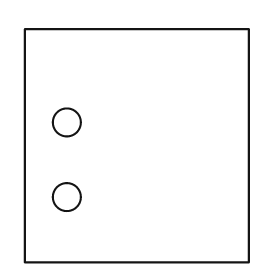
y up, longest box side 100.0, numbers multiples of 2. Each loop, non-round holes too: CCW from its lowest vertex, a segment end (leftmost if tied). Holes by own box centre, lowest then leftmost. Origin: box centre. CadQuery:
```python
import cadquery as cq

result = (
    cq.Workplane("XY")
    .moveTo(-48.0, -50.0)
    .lineTo(48.0, -50.0)
    .lineTo(48.0, 50.0)
    .lineTo(-48.0, 50.0)
    .close()
    .moveTo(-30.0, -22.0)
    .circle(6.0)
    .moveTo(-30.0, 10.0)
    .circle(6.0)
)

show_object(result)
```